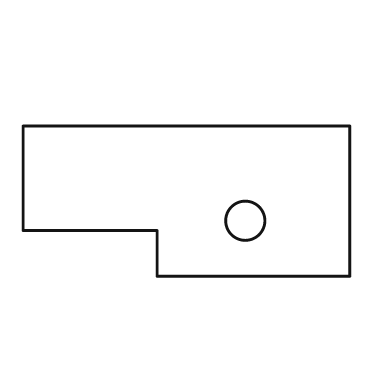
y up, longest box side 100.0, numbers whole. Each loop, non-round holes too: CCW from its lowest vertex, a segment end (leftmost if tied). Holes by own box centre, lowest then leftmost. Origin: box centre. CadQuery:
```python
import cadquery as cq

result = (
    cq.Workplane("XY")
    .moveTo(-9.0, -23.0)
    .lineTo(50.0, -23.0)
    .lineTo(50.0, 23.0)
    .lineTo(-50.0, 23.0)
    .lineTo(-50.0, -9.0)
    .lineTo(-9.0, -9.0)
    .close()
    .moveTo(18.0, -6.0)
    .circle(6.0)
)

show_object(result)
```